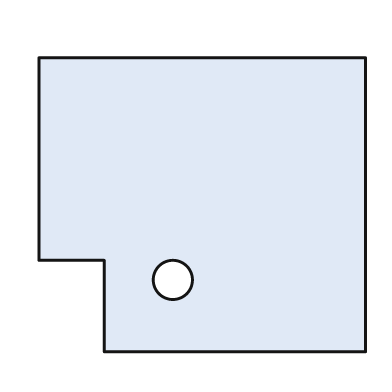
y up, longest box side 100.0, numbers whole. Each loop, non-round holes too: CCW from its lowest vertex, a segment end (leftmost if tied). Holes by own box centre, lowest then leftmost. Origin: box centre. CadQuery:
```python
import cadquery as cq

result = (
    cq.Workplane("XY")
    .moveTo(-30.0, -45.0)
    .lineTo(50.0, -45.0)
    .lineTo(50.0, 45.0)
    .lineTo(-50.0, 45.0)
    .lineTo(-50.0, -17.0)
    .lineTo(-30.0, -17.0)
    .close()
    .moveTo(-9.0, -23.0)
    .circle(6.0)
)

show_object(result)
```